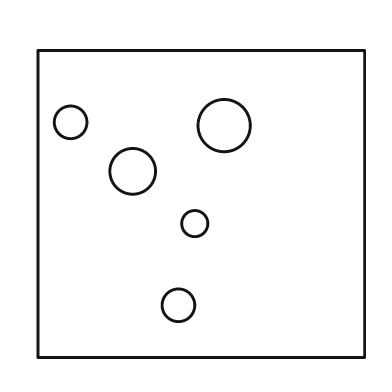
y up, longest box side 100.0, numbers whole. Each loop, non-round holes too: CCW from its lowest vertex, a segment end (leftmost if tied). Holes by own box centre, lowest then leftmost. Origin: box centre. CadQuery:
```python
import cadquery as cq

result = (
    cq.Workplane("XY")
    .moveTo(-50.0, -47.0)
    .lineTo(50.0, -47.0)
    .lineTo(50.0, 47.0)
    .lineTo(-50.0, 47.0)
    .close()
    .moveTo(-7.0, -31.0)
    .circle(5.0)
    .moveTo(-2.0, -6.0)
    .circle(4.0)
    .moveTo(-21.0, 10.0)
    .circle(7.0)
    .moveTo(7.0, 24.0)
    .circle(8.0)
    .moveTo(-40.0, 25.0)
    .circle(5.0)
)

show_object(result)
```